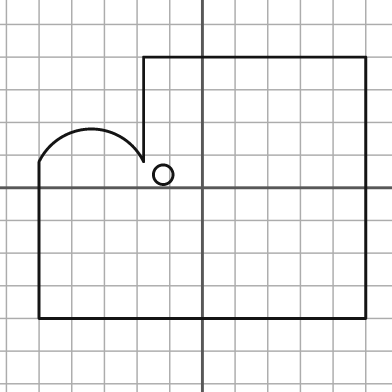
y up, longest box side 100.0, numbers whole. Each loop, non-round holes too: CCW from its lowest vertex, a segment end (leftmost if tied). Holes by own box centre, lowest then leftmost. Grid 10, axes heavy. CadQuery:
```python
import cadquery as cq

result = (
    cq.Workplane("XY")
    .moveTo(-50.0, -40.0)
    .lineTo(50.0, -40.0)
    .lineTo(50.0, 40.0)
    .lineTo(-18.0, 40.0)
    .lineTo(-18.0, 8.0)
    .threePointArc((-34.0, 18.0), (-50.0, 8.0))
    .close()
    .moveTo(-12.0, 4.0)
    .circle(3.0)
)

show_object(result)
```